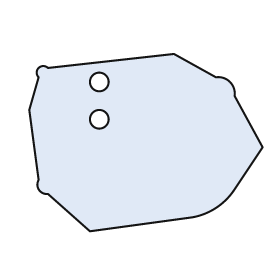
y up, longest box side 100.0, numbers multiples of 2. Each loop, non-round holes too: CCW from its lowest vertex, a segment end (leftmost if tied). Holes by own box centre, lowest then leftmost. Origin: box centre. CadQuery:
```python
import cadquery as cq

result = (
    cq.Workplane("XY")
    .moveTo(-24.0, -38.0)
    .lineTo(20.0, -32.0)
    .threePointArc((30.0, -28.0), (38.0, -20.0))
    .lineTo(50.0, -2.0)
    .lineTo(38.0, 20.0)
    .threePointArc((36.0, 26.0), (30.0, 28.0))
    .lineTo(12.0, 38.0)
    .lineTo(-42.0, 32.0)
    .threePointArc((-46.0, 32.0), (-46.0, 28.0))
    .lineTo(-50.0, 14.0)
    .lineTo(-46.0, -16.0)
    .threePointArc((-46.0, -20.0), (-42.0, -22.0))
    .close()
    .moveTo(-20.0, 10.0)
    .circle(4.0)
    .moveTo(-20.0, 26.0)
    .circle(4.0)
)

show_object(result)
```